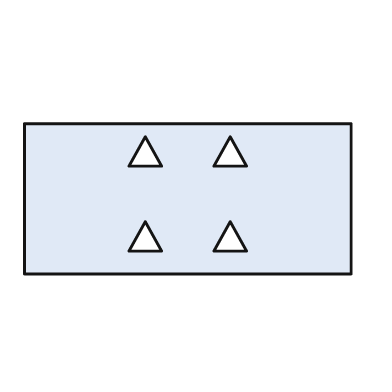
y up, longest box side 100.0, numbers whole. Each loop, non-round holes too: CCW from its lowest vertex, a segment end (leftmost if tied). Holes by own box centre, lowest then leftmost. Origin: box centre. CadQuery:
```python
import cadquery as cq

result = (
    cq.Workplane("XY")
    .moveTo(-50.0, -23.0)
    .lineTo(50.0, -23.0)
    .lineTo(50.0, 23.0)
    .lineTo(-50.0, 23.0)
    .close()
    .moveTo(-18.0, -16.0)
    .lineTo(-8.0, -16.0)
    .lineTo(-13.0, -7.0)
    .close()
    .moveTo(8.0, -16.0)
    .lineTo(18.0, -16.0)
    .lineTo(13.0, -7.0)
    .close()
    .moveTo(-18.0, 10.0)
    .lineTo(-8.0, 10.0)
    .lineTo(-13.0, 19.0)
    .close()
    .moveTo(8.0, 10.0)
    .lineTo(18.0, 10.0)
    .lineTo(13.0, 19.0)
    .close()
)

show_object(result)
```